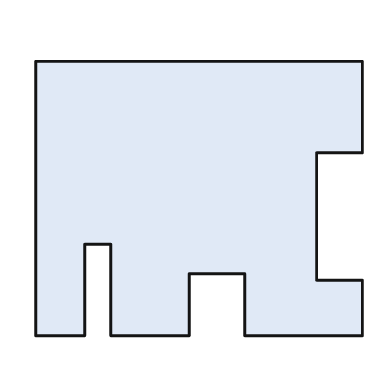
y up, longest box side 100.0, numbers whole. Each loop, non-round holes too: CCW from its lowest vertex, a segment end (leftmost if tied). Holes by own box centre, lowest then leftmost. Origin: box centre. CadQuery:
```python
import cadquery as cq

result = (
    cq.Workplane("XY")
    .moveTo(-50.0, -42.0)
    .lineTo(-35.0, -42.0)
    .lineTo(-35.0, -14.0)
    .lineTo(-27.0, -14.0)
    .lineTo(-27.0, -42.0)
    .lineTo(-3.0, -42.0)
    .lineTo(-3.0, -23.0)
    .lineTo(14.0, -23.0)
    .lineTo(14.0, -42.0)
    .lineTo(50.0, -42.0)
    .lineTo(50.0, -25.0)
    .lineTo(36.0, -25.0)
    .lineTo(36.0, 14.0)
    .lineTo(50.0, 14.0)
    .lineTo(50.0, 42.0)
    .lineTo(-50.0, 42.0)
    .close()
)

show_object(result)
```